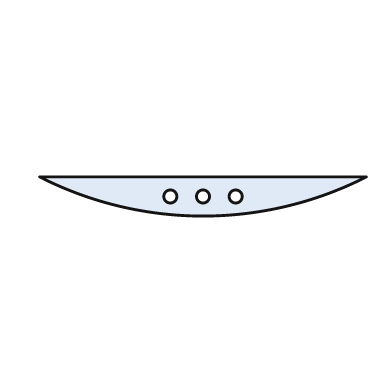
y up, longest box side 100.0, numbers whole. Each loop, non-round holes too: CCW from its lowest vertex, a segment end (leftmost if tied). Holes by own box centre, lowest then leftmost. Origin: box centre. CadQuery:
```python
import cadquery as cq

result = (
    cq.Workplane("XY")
    .moveTo(-50.0, 6.0)
    .threePointArc((0.0, -6.0), (50.0, 6.0))
    .close()
    .moveTo(-10.0, 0.0)
    .circle(2.0)
    .moveTo(0.0, 0.0)
    .circle(2.0)
    .moveTo(10.0, 0.0)
    .circle(2.0)
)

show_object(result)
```